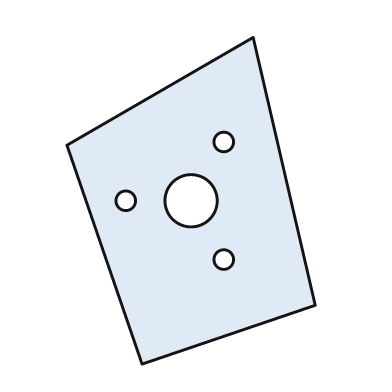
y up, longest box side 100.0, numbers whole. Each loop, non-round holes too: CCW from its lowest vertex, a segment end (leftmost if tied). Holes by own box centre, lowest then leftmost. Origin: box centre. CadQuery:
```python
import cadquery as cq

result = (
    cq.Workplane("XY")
    .moveTo(-15.0, -50.0)
    .lineTo(38.0, -32.0)
    .lineTo(19.0, 50.0)
    .lineTo(-38.0, 17.0)
    .close()
    .moveTo(10.0, -18.0)
    .circle(3.0)
    .moveTo(-20.0, 0.0)
    .circle(3.0)
    .moveTo(0.0, 0.0)
    .circle(8.0)
    .moveTo(10.0, 18.0)
    .circle(3.0)
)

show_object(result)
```